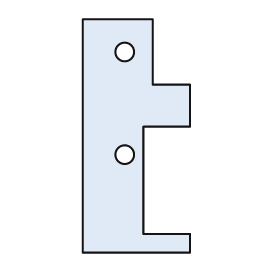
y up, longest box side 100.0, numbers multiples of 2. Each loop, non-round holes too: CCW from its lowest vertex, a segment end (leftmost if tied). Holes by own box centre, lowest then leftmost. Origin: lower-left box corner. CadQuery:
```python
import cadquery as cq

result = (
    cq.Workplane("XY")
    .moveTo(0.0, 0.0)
    .lineTo(46.0, 0.0)
    .lineTo(46.0, 8.0)
    .lineTo(26.0, 8.0)
    .lineTo(26.0, 54.0)
    .lineTo(46.0, 54.0)
    .lineTo(46.0, 72.0)
    .lineTo(30.0, 72.0)
    .lineTo(30.0, 100.0)
    .lineTo(0.0, 100.0)
    .close()
    .moveTo(18.0, 42.0)
    .circle(4.0)
    .moveTo(18.0, 86.0)
    .circle(4.0)
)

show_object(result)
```